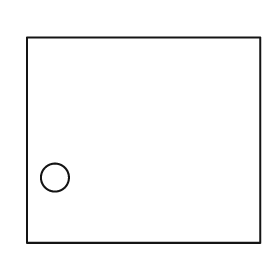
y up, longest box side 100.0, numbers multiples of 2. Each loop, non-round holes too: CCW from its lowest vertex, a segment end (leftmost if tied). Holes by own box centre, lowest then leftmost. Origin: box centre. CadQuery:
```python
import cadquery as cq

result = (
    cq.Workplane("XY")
    .moveTo(-50.0, -44.0)
    .lineTo(50.0, -44.0)
    .lineTo(50.0, 44.0)
    .lineTo(-50.0, 44.0)
    .close()
    .moveTo(-38.0, -16.0)
    .circle(6.0)
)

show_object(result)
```